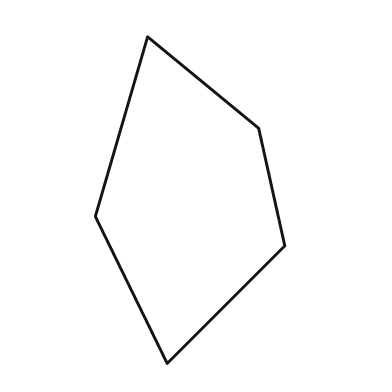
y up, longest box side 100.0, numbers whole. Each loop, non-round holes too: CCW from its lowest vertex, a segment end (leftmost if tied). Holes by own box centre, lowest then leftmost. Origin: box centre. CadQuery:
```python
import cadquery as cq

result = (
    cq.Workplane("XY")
    .moveTo(-7.0, -50.0)
    .lineTo(29.0, -14.0)
    .lineTo(21.0, 22.0)
    .lineTo(-13.0, 50.0)
    .lineTo(-29.0, -5.0)
    .close()
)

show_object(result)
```